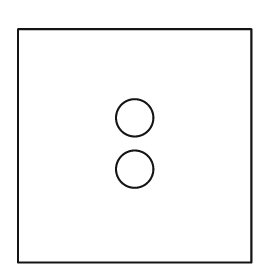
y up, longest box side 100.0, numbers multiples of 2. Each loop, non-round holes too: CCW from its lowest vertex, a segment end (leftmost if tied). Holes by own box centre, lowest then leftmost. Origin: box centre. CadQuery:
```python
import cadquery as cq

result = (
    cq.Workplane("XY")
    .moveTo(-50.0, -50.0)
    .lineTo(50.0, -50.0)
    .lineTo(50.0, 50.0)
    .lineTo(-50.0, 50.0)
    .close()
    .moveTo(0.0, -10.0)
    .circle(8.0)
    .moveTo(0.0, 12.0)
    .circle(8.0)
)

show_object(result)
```